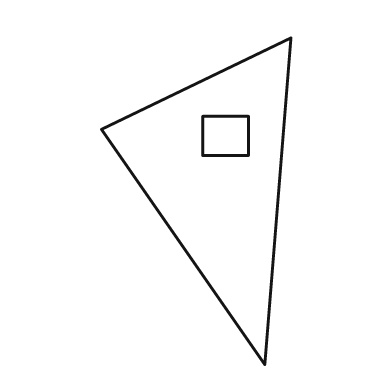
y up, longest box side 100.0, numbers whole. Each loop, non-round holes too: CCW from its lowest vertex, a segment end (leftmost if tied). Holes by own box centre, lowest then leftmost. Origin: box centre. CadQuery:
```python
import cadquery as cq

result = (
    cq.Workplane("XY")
    .moveTo(21.0, -50.0)
    .lineTo(29.0, 50.0)
    .lineTo(-29.0, 22.0)
    .close()
    .moveTo(2.0, 14.0)
    .lineTo(16.0, 14.0)
    .lineTo(16.0, 26.0)
    .lineTo(2.0, 26.0)
    .close()
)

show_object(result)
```